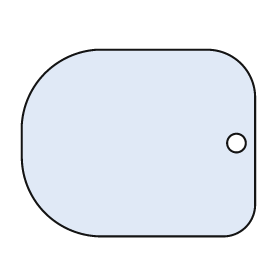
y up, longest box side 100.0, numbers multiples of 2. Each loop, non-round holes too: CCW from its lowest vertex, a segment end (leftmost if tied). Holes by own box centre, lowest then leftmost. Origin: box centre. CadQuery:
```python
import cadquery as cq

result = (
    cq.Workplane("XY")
    .moveTo(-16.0, -40.0)
    .lineTo(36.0, -40.0)
    .threePointArc((46.0, -36.0), (50.0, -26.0))
    .lineTo(50.0, 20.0)
    .threePointArc((44.0, 34.0), (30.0, 40.0))
    .lineTo(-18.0, 40.0)
    .threePointArc((-40.0, 30.0), (-50.0, 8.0))
    .lineTo(-50.0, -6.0)
    .threePointArc((-40.0, -30.0), (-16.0, -40.0))
    .close()
    .moveTo(42.0, 0.0)
    .circle(4.0)
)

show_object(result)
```